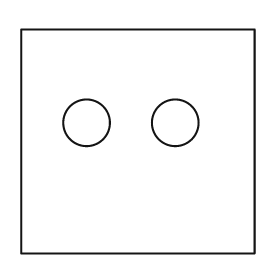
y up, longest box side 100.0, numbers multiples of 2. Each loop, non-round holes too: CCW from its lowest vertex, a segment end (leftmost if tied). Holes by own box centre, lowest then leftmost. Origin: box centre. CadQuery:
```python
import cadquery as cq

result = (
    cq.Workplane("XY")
    .moveTo(-50.0, -48.0)
    .lineTo(50.0, -48.0)
    .lineTo(50.0, 48.0)
    .lineTo(-50.0, 48.0)
    .close()
    .moveTo(-22.0, 8.0)
    .circle(10.0)
    .moveTo(16.0, 8.0)
    .circle(10.0)
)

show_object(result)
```